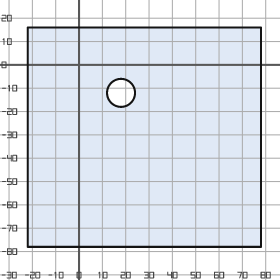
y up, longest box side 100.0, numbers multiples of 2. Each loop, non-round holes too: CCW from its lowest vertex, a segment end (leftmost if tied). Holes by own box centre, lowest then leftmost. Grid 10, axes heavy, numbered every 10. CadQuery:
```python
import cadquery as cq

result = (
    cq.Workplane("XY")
    .moveTo(-22.0, -78.0)
    .lineTo(78.0, -78.0)
    .lineTo(78.0, 16.0)
    .lineTo(-22.0, 16.0)
    .close()
    .moveTo(18.0, -12.0)
    .circle(6.0)
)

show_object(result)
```